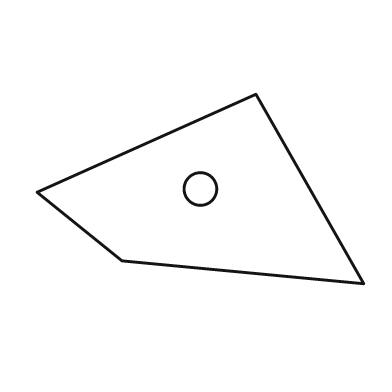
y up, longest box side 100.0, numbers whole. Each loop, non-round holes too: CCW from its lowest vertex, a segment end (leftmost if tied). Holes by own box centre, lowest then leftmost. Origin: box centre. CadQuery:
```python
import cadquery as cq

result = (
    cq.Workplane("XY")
    .moveTo(50.0, -29.0)
    .lineTo(17.0, 29.0)
    .lineTo(-50.0, -1.0)
    .lineTo(-24.0, -22.0)
    .close()
    .moveTo(0.0, 0.0)
    .circle(5.0)
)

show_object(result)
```